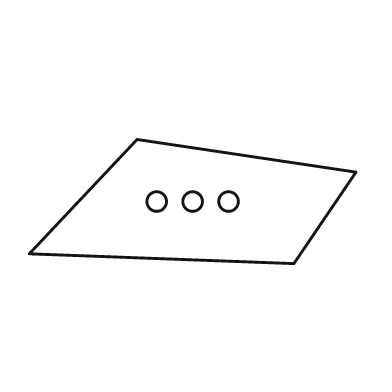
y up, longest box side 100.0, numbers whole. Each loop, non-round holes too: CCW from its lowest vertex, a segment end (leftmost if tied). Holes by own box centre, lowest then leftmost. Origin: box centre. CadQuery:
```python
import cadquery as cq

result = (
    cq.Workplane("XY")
    .moveTo(31.0, -19.0)
    .lineTo(50.0, 9.0)
    .lineTo(-17.0, 19.0)
    .lineTo(-50.0, -16.0)
    .close()
    .moveTo(-11.0, 0.0)
    .circle(3.0)
    .moveTo(0.0, 0.0)
    .circle(3.0)
    .moveTo(11.0, 0.0)
    .circle(3.0)
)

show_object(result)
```